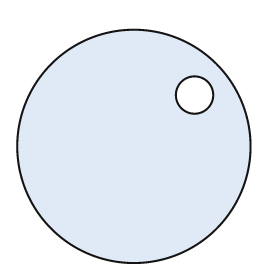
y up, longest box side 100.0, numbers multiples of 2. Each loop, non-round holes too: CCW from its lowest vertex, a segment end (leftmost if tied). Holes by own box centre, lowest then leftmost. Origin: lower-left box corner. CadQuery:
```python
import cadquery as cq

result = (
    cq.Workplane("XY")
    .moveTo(50.0, 50.0)
    .circle(50.0)
    .moveTo(76.0, 72.0)
    .circle(8.0)
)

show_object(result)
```